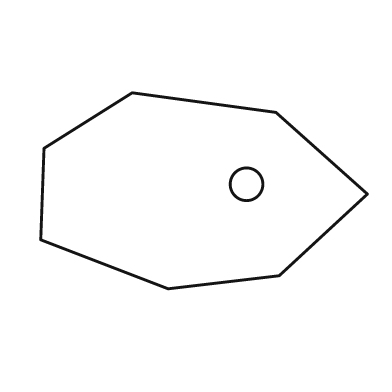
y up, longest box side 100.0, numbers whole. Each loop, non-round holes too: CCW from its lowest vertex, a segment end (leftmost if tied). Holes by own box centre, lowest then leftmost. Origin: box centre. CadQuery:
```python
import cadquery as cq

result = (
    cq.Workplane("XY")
    .moveTo(-11.0, -30.0)
    .lineTo(23.0, -26.0)
    .lineTo(50.0, -1.0)
    .lineTo(22.0, 24.0)
    .lineTo(-22.0, 30.0)
    .lineTo(-49.0, 13.0)
    .lineTo(-50.0, -15.0)
    .close()
    .moveTo(13.0, 2.0)
    .circle(5.0)
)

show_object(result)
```